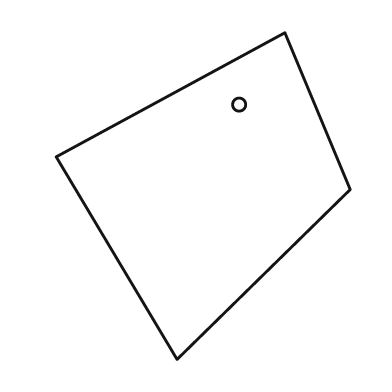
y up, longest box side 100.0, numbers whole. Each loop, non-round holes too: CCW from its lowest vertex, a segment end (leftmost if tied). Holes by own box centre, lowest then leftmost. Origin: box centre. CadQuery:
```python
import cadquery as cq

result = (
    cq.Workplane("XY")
    .moveTo(-8.0, -50.0)
    .lineTo(45.0, 2.0)
    .lineTo(25.0, 50.0)
    .lineTo(-45.0, 12.0)
    .close()
    .moveTo(11.0, 28.0)
    .circle(2.0)
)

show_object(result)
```